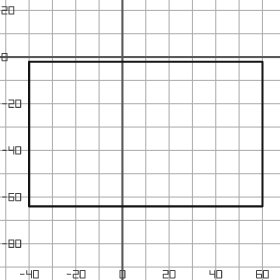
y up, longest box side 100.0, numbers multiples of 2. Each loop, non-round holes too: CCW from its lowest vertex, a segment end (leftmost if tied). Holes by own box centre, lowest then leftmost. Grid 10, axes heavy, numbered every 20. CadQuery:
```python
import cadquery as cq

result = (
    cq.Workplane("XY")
    .moveTo(-40.0, -64.0)
    .lineTo(60.0, -64.0)
    .lineTo(60.0, -2.0)
    .lineTo(-40.0, -2.0)
    .close()
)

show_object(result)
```